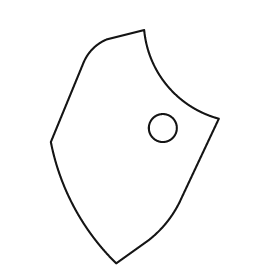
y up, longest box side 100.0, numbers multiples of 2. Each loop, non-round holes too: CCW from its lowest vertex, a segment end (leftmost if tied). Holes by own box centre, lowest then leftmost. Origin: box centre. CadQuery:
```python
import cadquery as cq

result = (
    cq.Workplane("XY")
    .moveTo(-8.0, -50.0)
    .lineTo(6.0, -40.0)
    .threePointArc((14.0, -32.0), (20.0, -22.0))
    .lineTo(36.0, 12.0)
    .threePointArc((14.0, 26.0), (4.0, 50.0))
    .lineTo(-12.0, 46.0)
    .threePointArc((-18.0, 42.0), (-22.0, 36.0))
    .lineTo(-36.0, 2.0)
    .threePointArc((-26.0, -26.0), (-8.0, -50.0))
    .close()
    .moveTo(12.0, 8.0)
    .circle(6.0)
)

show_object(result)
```